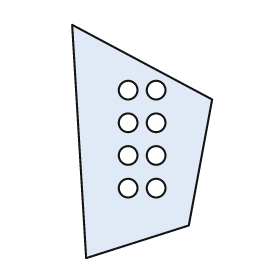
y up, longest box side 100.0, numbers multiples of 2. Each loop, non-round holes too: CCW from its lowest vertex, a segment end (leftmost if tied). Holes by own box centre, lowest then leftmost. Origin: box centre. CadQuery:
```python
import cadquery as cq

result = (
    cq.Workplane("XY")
    .moveTo(-24.0, -50.0)
    .lineTo(20.0, -36.0)
    .lineTo(30.0, 18.0)
    .lineTo(-30.0, 50.0)
    .close()
    .moveTo(-6.0, -20.0)
    .circle(4.0)
    .moveTo(6.0, -20.0)
    .circle(4.0)
    .moveTo(-6.0, -6.0)
    .circle(4.0)
    .moveTo(6.0, -6.0)
    .circle(4.0)
    .moveTo(-6.0, 8.0)
    .circle(4.0)
    .moveTo(6.0, 8.0)
    .circle(4.0)
    .moveTo(-6.0, 22.0)
    .circle(4.0)
    .moveTo(6.0, 22.0)
    .circle(4.0)
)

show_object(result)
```